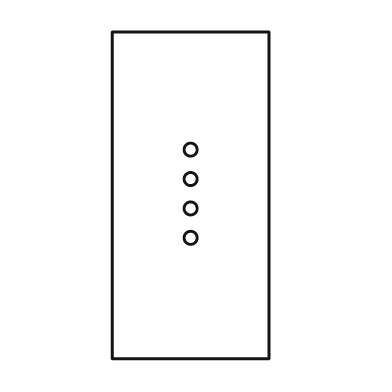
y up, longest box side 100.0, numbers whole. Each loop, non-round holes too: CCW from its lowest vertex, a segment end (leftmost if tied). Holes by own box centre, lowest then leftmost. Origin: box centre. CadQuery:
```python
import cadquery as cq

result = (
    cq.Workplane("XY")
    .moveTo(-24.0, -50.0)
    .lineTo(24.0, -50.0)
    .lineTo(24.0, 50.0)
    .lineTo(-24.0, 50.0)
    .close()
    .moveTo(0.0, -13.0)
    .circle(2.0)
    .moveTo(0.0, -4.0)
    .circle(2.0)
    .moveTo(0.0, 5.0)
    .circle(2.0)
    .moveTo(0.0, 14.0)
    .circle(2.0)
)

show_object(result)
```